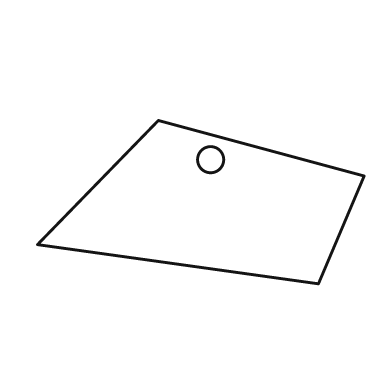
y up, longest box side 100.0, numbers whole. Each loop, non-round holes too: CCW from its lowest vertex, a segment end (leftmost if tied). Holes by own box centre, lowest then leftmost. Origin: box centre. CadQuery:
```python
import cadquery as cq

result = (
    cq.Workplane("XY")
    .moveTo(36.0, -25.0)
    .lineTo(50.0, 8.0)
    .lineTo(-13.0, 25.0)
    .lineTo(-50.0, -13.0)
    .close()
    .moveTo(3.0, 13.0)
    .circle(4.0)
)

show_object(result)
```